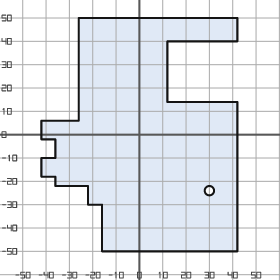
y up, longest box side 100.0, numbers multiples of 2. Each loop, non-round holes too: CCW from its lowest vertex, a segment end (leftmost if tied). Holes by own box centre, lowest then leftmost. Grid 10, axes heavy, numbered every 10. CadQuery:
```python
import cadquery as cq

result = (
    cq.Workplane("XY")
    .moveTo(-16.0, -50.0)
    .lineTo(42.0, -50.0)
    .lineTo(42.0, 14.0)
    .lineTo(12.0, 14.0)
    .lineTo(12.0, 40.0)
    .lineTo(42.0, 40.0)
    .lineTo(42.0, 50.0)
    .lineTo(-26.0, 50.0)
    .lineTo(-26.0, 6.0)
    .lineTo(-42.0, 6.0)
    .lineTo(-42.0, -2.0)
    .lineTo(-36.0, -2.0)
    .lineTo(-36.0, -10.0)
    .lineTo(-42.0, -10.0)
    .lineTo(-42.0, -18.0)
    .lineTo(-36.0, -18.0)
    .lineTo(-36.0, -22.0)
    .lineTo(-22.0, -22.0)
    .lineTo(-22.0, -30.0)
    .lineTo(-16.0, -30.0)
    .close()
    .moveTo(30.0, -24.0)
    .circle(2.0)
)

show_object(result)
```